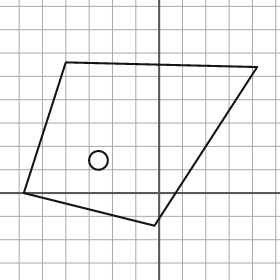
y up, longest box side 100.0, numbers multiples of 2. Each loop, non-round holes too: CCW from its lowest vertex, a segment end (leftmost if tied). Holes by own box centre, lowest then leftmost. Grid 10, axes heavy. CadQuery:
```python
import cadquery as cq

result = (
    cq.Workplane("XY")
    .moveTo(-2.0, -14.0)
    .lineTo(42.0, 54.0)
    .lineTo(-40.0, 56.0)
    .lineTo(-58.0, 0.0)
    .close()
    .moveTo(-26.0, 14.0)
    .circle(4.0)
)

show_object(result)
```